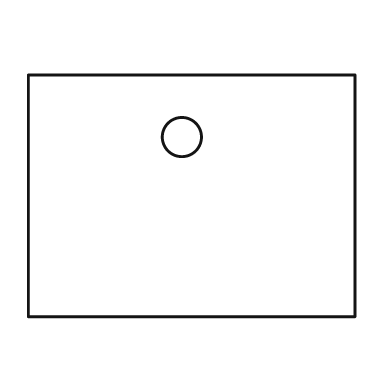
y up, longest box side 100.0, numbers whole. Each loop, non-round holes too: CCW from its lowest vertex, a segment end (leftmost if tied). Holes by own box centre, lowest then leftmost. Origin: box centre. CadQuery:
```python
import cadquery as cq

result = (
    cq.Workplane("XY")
    .moveTo(-50.0, -37.0)
    .lineTo(50.0, -37.0)
    .lineTo(50.0, 37.0)
    .lineTo(-50.0, 37.0)
    .close()
    .moveTo(-3.0, 18.0)
    .circle(6.0)
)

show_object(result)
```